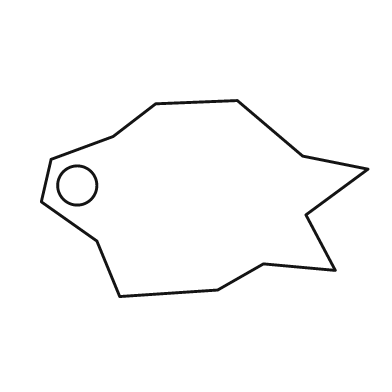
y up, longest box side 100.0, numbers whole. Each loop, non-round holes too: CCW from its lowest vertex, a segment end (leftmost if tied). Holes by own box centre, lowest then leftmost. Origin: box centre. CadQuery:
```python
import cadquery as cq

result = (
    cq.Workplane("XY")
    .moveTo(-26.0, -30.0)
    .lineTo(4.0, -28.0)
    .lineTo(18.0, -20.0)
    .lineTo(40.0, -22.0)
    .lineTo(31.0, -5.0)
    .lineTo(50.0, 9.0)
    .lineTo(30.0, 13.0)
    .lineTo(10.0, 30.0)
    .lineTo(-15.0, 29.0)
    .lineTo(-28.0, 19.0)
    .lineTo(-47.0, 12.0)
    .lineTo(-50.0, -1.0)
    .lineTo(-33.0, -13.0)
    .close()
    .moveTo(-39.0, 4.0)
    .circle(6.0)
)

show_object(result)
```